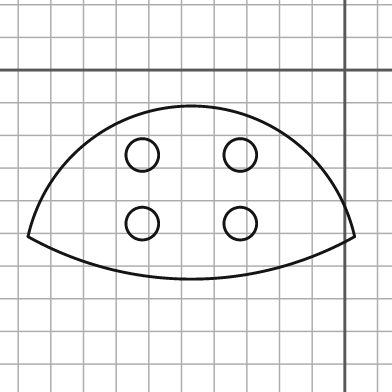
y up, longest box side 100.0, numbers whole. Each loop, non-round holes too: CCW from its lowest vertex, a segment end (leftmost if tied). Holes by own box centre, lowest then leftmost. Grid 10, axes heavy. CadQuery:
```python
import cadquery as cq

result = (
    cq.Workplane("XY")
    .moveTo(-97.0, -51.0)
    .threePointArc((-47.0, -64.0), (3.0, -51.0))
    .threePointArc((-47.0, -11.0), (-97.0, -51.0))
    .close()
    .moveTo(-62.0, -47.0)
    .circle(5.0)
    .moveTo(-32.0, -47.0)
    .circle(5.0)
    .moveTo(-62.0, -26.0)
    .circle(5.0)
    .moveTo(-32.0, -26.0)
    .circle(5.0)
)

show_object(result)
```